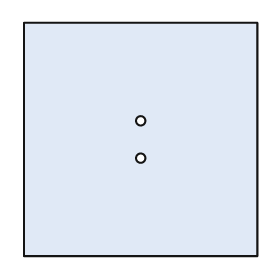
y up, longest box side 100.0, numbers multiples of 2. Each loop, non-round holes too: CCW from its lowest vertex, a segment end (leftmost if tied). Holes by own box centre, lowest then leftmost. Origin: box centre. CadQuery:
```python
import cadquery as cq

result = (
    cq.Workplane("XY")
    .moveTo(-50.0, -50.0)
    .lineTo(50.0, -50.0)
    .lineTo(50.0, 50.0)
    .lineTo(-50.0, 50.0)
    .close()
    .moveTo(0.0, -8.0)
    .circle(2.0)
    .moveTo(0.0, 8.0)
    .circle(2.0)
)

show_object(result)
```